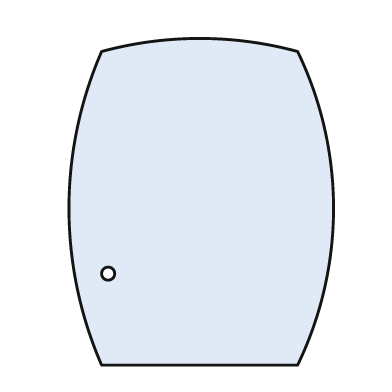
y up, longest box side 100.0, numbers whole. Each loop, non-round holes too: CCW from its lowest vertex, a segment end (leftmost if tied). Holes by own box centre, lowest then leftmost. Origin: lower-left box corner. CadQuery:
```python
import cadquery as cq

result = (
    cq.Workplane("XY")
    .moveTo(10.0, 0.0)
    .lineTo(70.0, 0.0)
    .threePointArc((81.0, 48.0), (70.0, 96.0))
    .threePointArc((40.0, 100.0), (10.0, 96.0))
    .threePointArc((0.0, 48.0), (10.0, 0.0))
    .close()
    .moveTo(12.0, 28.0)
    .circle(2.0)
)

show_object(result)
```